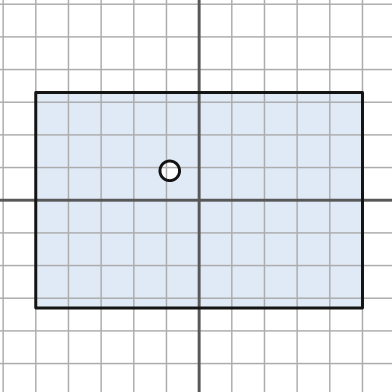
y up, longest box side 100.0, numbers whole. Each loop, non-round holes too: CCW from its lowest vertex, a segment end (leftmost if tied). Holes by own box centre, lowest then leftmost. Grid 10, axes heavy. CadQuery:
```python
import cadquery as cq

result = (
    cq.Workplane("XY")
    .moveTo(-50.0, -33.0)
    .lineTo(50.0, -33.0)
    .lineTo(50.0, 33.0)
    .lineTo(-50.0, 33.0)
    .close()
    .moveTo(-9.0, 9.0)
    .circle(3.0)
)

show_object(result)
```